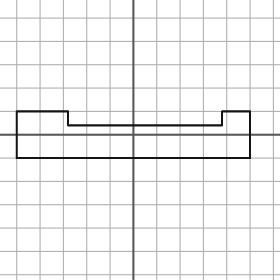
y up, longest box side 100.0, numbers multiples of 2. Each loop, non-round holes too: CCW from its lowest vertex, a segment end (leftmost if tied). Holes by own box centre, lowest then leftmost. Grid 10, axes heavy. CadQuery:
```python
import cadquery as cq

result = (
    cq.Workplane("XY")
    .moveTo(-50.0, -10.0)
    .lineTo(50.0, -10.0)
    .lineTo(50.0, 10.0)
    .lineTo(38.0, 10.0)
    .lineTo(38.0, 4.0)
    .lineTo(-28.0, 4.0)
    .lineTo(-28.0, 10.0)
    .lineTo(-50.0, 10.0)
    .close()
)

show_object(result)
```